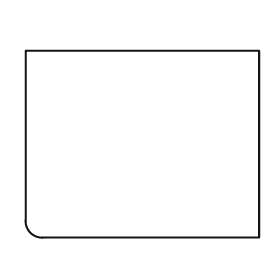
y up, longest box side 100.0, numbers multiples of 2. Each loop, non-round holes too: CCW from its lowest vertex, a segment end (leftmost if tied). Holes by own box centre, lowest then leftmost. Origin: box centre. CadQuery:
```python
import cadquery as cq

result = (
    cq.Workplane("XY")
    .moveTo(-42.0, -40.0)
    .lineTo(50.0, -40.0)
    .lineTo(50.0, 40.0)
    .lineTo(-50.0, 40.0)
    .lineTo(-50.0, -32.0)
    .threePointArc((-48.0, -38.0), (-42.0, -40.0))
    .close()
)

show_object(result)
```